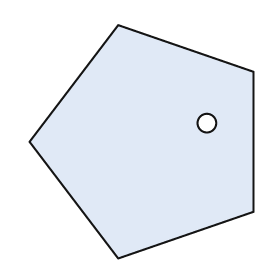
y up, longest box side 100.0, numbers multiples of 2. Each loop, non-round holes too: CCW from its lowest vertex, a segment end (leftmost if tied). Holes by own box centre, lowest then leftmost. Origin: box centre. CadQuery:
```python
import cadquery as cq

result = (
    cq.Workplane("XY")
    .moveTo(-10.0, -50.0)
    .lineTo(48.0, -30.0)
    .lineTo(48.0, 30.0)
    .lineTo(-10.0, 50.0)
    .lineTo(-48.0, 0.0)
    .close()
    .moveTo(28.0, 8.0)
    .circle(4.0)
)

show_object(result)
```